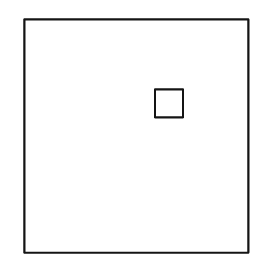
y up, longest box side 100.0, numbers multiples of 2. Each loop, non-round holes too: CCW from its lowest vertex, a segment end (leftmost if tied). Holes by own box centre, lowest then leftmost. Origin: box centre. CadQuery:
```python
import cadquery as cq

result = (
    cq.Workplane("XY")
    .moveTo(-48.0, -50.0)
    .lineTo(48.0, -50.0)
    .lineTo(48.0, 50.0)
    .lineTo(-48.0, 50.0)
    .close()
    .moveTo(8.0, 8.0)
    .lineTo(20.0, 8.0)
    .lineTo(20.0, 20.0)
    .lineTo(8.0, 20.0)
    .close()
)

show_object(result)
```